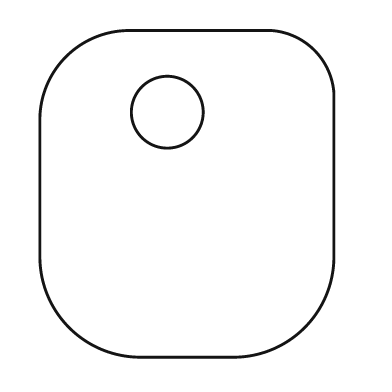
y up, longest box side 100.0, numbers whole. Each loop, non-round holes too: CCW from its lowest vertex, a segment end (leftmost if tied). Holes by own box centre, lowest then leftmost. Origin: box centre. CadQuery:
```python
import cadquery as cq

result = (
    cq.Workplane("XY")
    .moveTo(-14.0, -50.0)
    .lineTo(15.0, -50.0)
    .threePointArc((36.0, -41.0), (45.0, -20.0))
    .lineTo(45.0, 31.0)
    .threePointArc((39.0, 44.0), (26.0, 50.0))
    .lineTo(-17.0, 50.0)
    .threePointArc((-37.0, 42.0), (-45.0, 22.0))
    .lineTo(-45.0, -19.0)
    .threePointArc((-36.0, -41.0), (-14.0, -50.0))
    .close()
    .moveTo(-6.0, 25.0)
    .circle(11.0)
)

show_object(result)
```